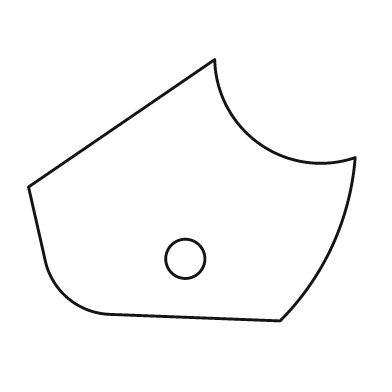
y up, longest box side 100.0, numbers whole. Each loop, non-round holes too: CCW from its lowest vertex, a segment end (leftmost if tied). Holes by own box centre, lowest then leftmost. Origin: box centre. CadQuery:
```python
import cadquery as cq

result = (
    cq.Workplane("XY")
    .moveTo(27.0, -40.0)
    .threePointArc((43.0, -17.0), (50.0, 10.0))
    .threePointArc((21.0, 14.0), (7.0, 40.0))
    .lineTo(-50.0, 1.0)
    .lineTo(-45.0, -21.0)
    .threePointArc((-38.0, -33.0), (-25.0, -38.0))
    .close()
    .moveTo(-2.0, -21.0)
    .circle(6.0)
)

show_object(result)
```